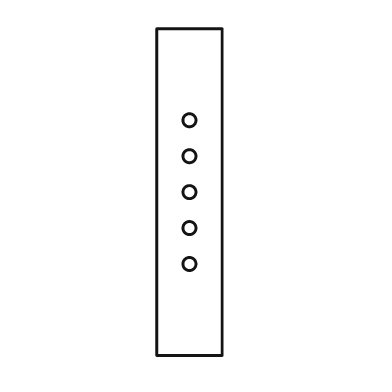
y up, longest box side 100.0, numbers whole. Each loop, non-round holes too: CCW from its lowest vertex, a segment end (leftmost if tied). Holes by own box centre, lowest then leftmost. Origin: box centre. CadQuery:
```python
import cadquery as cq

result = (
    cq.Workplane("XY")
    .moveTo(-10.0, -50.0)
    .lineTo(10.0, -50.0)
    .lineTo(10.0, 50.0)
    .lineTo(-10.0, 50.0)
    .close()
    .moveTo(0.0, -22.0)
    .circle(2.0)
    .moveTo(0.0, -11.0)
    .circle(2.0)
    .moveTo(0.0, 0.0)
    .circle(2.0)
    .moveTo(0.0, 11.0)
    .circle(2.0)
    .moveTo(0.0, 22.0)
    .circle(2.0)
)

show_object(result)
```